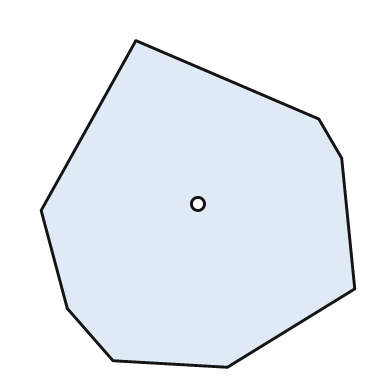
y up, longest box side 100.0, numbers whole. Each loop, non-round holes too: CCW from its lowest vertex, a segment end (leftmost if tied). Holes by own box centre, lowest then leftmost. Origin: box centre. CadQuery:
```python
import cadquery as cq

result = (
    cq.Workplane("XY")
    .moveTo(9.0, -50.0)
    .lineTo(48.0, -26.0)
    .lineTo(44.0, 14.0)
    .lineTo(37.0, 26.0)
    .lineTo(-19.0, 50.0)
    .lineTo(-48.0, -2.0)
    .lineTo(-40.0, -32.0)
    .lineTo(-26.0, -48.0)
    .close()
    .moveTo(0.0, 0.0)
    .circle(2.0)
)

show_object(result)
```